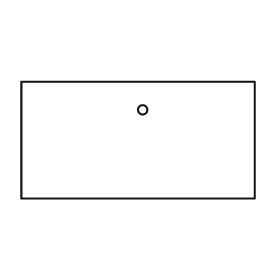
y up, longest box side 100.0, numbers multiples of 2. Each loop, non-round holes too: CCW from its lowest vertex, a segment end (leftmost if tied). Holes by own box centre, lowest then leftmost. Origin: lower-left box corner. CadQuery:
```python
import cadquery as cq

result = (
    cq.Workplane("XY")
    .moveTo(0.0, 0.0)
    .lineTo(100.0, 0.0)
    .lineTo(100.0, 50.0)
    .lineTo(0.0, 50.0)
    .close()
    .moveTo(52.0, 38.0)
    .circle(2.0)
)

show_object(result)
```